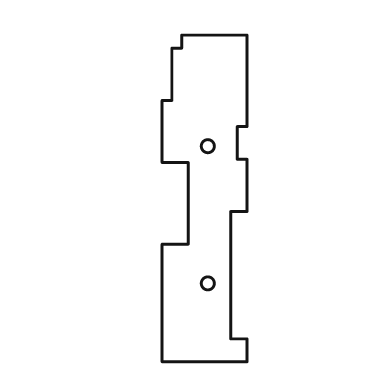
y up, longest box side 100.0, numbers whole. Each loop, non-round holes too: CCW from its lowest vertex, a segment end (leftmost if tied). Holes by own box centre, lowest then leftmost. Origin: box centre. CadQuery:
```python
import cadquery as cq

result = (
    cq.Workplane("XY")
    .moveTo(-13.0, -50.0)
    .lineTo(13.0, -50.0)
    .lineTo(13.0, -43.0)
    .lineTo(8.0, -43.0)
    .lineTo(8.0, -4.0)
    .lineTo(13.0, -4.0)
    .lineTo(13.0, 12.0)
    .lineTo(10.0, 12.0)
    .lineTo(10.0, 22.0)
    .lineTo(13.0, 22.0)
    .lineTo(13.0, 50.0)
    .lineTo(-7.0, 50.0)
    .lineTo(-7.0, 46.0)
    .lineTo(-10.0, 46.0)
    .lineTo(-10.0, 30.0)
    .lineTo(-13.0, 30.0)
    .lineTo(-13.0, 11.0)
    .lineTo(-5.0, 11.0)
    .lineTo(-5.0, -14.0)
    .lineTo(-13.0, -14.0)
    .close()
    .moveTo(1.0, -26.0)
    .circle(2.0)
    .moveTo(1.0, 16.0)
    .circle(2.0)
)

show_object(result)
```